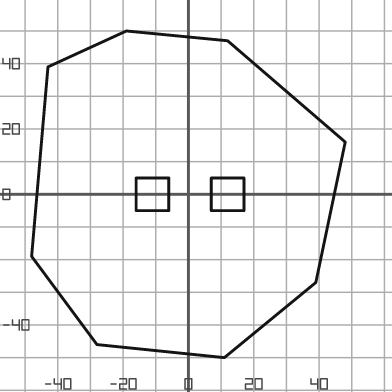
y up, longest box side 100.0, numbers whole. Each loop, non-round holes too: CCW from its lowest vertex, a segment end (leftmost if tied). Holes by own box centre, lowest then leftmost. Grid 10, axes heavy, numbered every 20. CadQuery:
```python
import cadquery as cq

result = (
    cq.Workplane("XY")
    .moveTo(11.0, -50.0)
    .lineTo(39.0, -27.0)
    .lineTo(48.0, 16.0)
    .lineTo(12.0, 47.0)
    .lineTo(-19.0, 50.0)
    .lineTo(-43.0, 39.0)
    .lineTo(-48.0, -19.0)
    .lineTo(-28.0, -46.0)
    .close()
    .moveTo(-16.0, -5.0)
    .lineTo(-6.0, -5.0)
    .lineTo(-6.0, 5.0)
    .lineTo(-16.0, 5.0)
    .close()
    .moveTo(7.0, -5.0)
    .lineTo(17.0, -5.0)
    .lineTo(17.0, 5.0)
    .lineTo(7.0, 5.0)
    .close()
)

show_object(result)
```